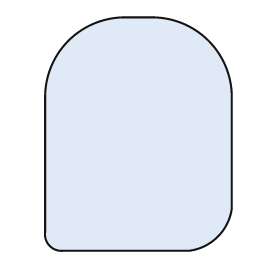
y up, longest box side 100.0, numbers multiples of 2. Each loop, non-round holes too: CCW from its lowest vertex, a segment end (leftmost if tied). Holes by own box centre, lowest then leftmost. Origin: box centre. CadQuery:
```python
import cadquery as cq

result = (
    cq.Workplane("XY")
    .moveTo(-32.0, -50.0)
    .lineTo(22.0, -50.0)
    .threePointArc((34.0, -44.0), (40.0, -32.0))
    .lineTo(40.0, 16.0)
    .threePointArc((30.0, 40.0), (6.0, 50.0))
    .lineTo(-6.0, 50.0)
    .threePointArc((-30.0, 40.0), (-40.0, 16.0))
    .lineTo(-40.0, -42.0)
    .threePointArc((-38.0, -48.0), (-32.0, -50.0))
    .close()
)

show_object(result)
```